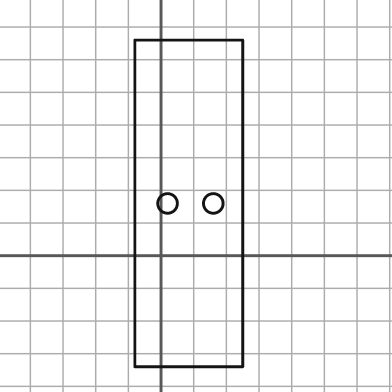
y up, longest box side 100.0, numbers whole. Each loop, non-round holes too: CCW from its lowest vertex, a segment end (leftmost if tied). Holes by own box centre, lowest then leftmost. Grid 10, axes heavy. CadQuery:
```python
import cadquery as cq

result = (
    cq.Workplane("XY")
    .moveTo(-8.0, -34.0)
    .lineTo(25.0, -34.0)
    .lineTo(25.0, 66.0)
    .lineTo(-8.0, 66.0)
    .close()
    .moveTo(2.0, 16.0)
    .circle(3.0)
    .moveTo(16.0, 16.0)
    .circle(3.0)
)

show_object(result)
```